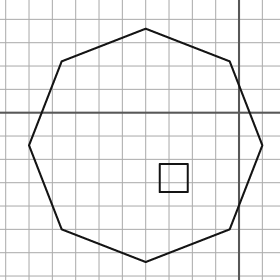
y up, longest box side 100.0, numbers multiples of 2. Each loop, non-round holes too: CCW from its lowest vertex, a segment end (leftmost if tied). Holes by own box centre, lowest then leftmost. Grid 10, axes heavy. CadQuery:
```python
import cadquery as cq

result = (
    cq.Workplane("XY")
    .moveTo(-40.0, -64.0)
    .lineTo(-4.0, -50.0)
    .lineTo(10.0, -14.0)
    .lineTo(-4.0, 22.0)
    .lineTo(-40.0, 36.0)
    .lineTo(-76.0, 22.0)
    .lineTo(-90.0, -14.0)
    .lineTo(-76.0, -50.0)
    .close()
    .moveTo(-34.0, -34.0)
    .lineTo(-22.0, -34.0)
    .lineTo(-22.0, -22.0)
    .lineTo(-34.0, -22.0)
    .close()
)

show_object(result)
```